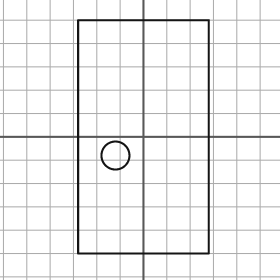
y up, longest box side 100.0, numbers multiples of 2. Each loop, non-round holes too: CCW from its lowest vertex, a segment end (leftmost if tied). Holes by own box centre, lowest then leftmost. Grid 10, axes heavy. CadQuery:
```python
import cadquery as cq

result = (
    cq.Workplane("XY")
    .moveTo(-28.0, -50.0)
    .lineTo(28.0, -50.0)
    .lineTo(28.0, 50.0)
    .lineTo(-28.0, 50.0)
    .close()
    .moveTo(-12.0, -8.0)
    .circle(6.0)
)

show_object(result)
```